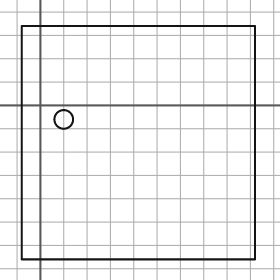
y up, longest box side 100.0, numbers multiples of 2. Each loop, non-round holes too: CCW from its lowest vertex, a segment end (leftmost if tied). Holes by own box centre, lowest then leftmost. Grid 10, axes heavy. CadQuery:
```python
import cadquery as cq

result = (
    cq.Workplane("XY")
    .moveTo(-8.0, -66.0)
    .lineTo(92.0, -66.0)
    .lineTo(92.0, 34.0)
    .lineTo(-8.0, 34.0)
    .close()
    .moveTo(10.0, -6.0)
    .circle(4.0)
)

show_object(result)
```